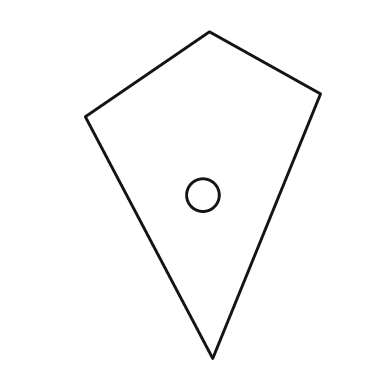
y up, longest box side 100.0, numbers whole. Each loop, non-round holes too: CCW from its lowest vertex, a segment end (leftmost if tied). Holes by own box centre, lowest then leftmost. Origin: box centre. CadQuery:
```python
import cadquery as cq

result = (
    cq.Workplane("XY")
    .moveTo(3.0, -50.0)
    .lineTo(36.0, 31.0)
    .lineTo(2.0, 50.0)
    .lineTo(-36.0, 24.0)
    .close()
    .moveTo(0.0, 0.0)
    .circle(5.0)
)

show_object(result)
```